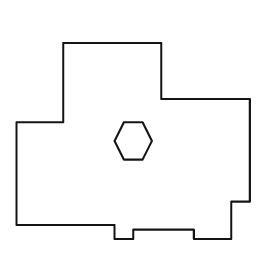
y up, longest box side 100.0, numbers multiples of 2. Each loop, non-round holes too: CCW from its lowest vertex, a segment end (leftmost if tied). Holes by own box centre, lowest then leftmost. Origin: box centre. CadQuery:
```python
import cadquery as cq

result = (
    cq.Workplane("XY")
    .moveTo(-8.0, -42.0)
    .lineTo(0.0, -42.0)
    .lineTo(0.0, -38.0)
    .lineTo(26.0, -38.0)
    .lineTo(26.0, -42.0)
    .lineTo(42.0, -42.0)
    .lineTo(42.0, -26.0)
    .lineTo(50.0, -26.0)
    .lineTo(50.0, 18.0)
    .lineTo(12.0, 18.0)
    .lineTo(12.0, 42.0)
    .lineTo(-30.0, 42.0)
    .lineTo(-30.0, 8.0)
    .lineTo(-50.0, 8.0)
    .lineTo(-50.0, -36.0)
    .lineTo(-8.0, -36.0)
    .close()
    .moveTo(-4.0, -8.0)
    .lineTo(4.0, -8.0)
    .lineTo(8.0, 0.0)
    .lineTo(4.0, 8.0)
    .lineTo(-4.0, 8.0)
    .lineTo(-8.0, 0.0)
    .close()
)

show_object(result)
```